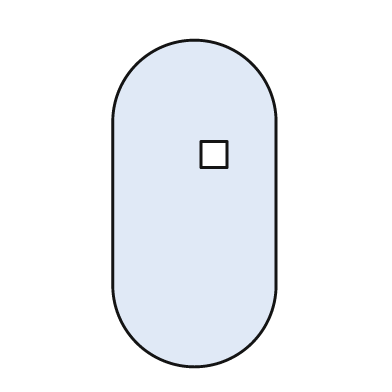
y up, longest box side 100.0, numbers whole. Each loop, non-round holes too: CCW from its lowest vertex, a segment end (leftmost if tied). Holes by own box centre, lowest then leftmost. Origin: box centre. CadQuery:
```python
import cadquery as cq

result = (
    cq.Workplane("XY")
    .moveTo(-25.0, -25.0)
    .threePointArc((0.0, -50.0), (25.0, -25.0))
    .lineTo(25.0, 25.0)
    .threePointArc((0.0, 50.0), (-25.0, 25.0))
    .close()
    .moveTo(2.0, 11.0)
    .lineTo(10.0, 11.0)
    .lineTo(10.0, 19.0)
    .lineTo(2.0, 19.0)
    .close()
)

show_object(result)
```